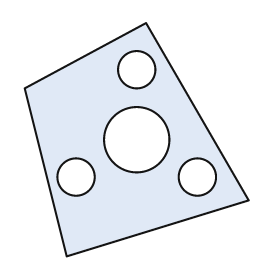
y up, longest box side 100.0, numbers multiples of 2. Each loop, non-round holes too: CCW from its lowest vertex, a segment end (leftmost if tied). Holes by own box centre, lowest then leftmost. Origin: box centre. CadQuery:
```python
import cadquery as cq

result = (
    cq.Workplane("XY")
    .moveTo(-30.0, -50.0)
    .lineTo(48.0, -26.0)
    .lineTo(4.0, 50.0)
    .lineTo(-48.0, 22.0)
    .close()
    .moveTo(-26.0, -16.0)
    .circle(8.0)
    .moveTo(26.0, -16.0)
    .circle(8.0)
    .moveTo(0.0, 0.0)
    .circle(14.0)
    .moveTo(0.0, 30.0)
    .circle(8.0)
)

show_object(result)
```